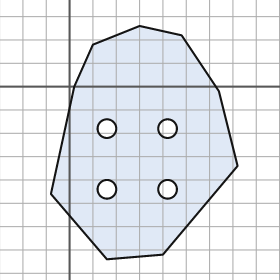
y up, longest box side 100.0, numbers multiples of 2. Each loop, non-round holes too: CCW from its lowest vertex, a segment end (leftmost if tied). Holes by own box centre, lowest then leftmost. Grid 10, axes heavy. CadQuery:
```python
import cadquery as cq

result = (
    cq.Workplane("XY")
    .moveTo(16.0, -74.0)
    .lineTo(40.0, -72.0)
    .lineTo(72.0, -34.0)
    .lineTo(64.0, -2.0)
    .lineTo(48.0, 22.0)
    .lineTo(30.0, 26.0)
    .lineTo(10.0, 18.0)
    .lineTo(2.0, 0.0)
    .lineTo(-8.0, -46.0)
    .close()
    .moveTo(16.0, -44.0)
    .circle(4.0)
    .moveTo(42.0, -44.0)
    .circle(4.0)
    .moveTo(16.0, -18.0)
    .circle(4.0)
    .moveTo(42.0, -18.0)
    .circle(4.0)
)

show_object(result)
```